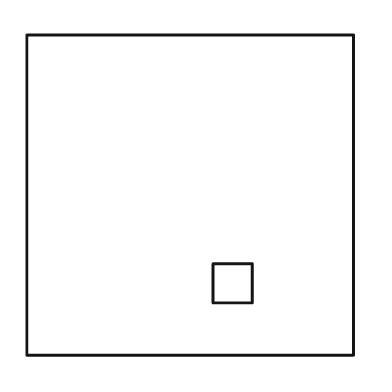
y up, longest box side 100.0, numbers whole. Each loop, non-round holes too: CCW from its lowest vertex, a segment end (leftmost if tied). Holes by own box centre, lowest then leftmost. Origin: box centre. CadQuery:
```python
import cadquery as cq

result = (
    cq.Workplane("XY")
    .moveTo(-50.0, -49.0)
    .lineTo(50.0, -49.0)
    .lineTo(50.0, 49.0)
    .lineTo(-50.0, 49.0)
    .close()
    .moveTo(7.0, -33.0)
    .lineTo(19.0, -33.0)
    .lineTo(19.0, -21.0)
    .lineTo(7.0, -21.0)
    .close()
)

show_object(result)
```